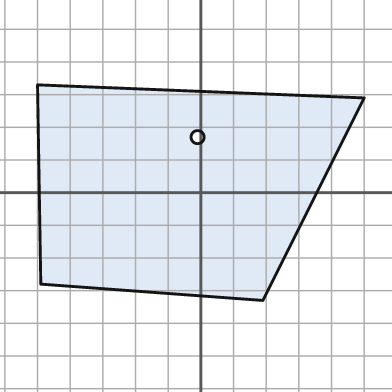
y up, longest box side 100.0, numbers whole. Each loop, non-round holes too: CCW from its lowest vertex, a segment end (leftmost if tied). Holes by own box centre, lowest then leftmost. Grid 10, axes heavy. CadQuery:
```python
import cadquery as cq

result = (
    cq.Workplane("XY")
    .moveTo(19.0, -33.0)
    .lineTo(50.0, 29.0)
    .lineTo(-50.0, 33.0)
    .lineTo(-49.0, -28.0)
    .close()
    .moveTo(-1.0, 17.0)
    .circle(2.0)
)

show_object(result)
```